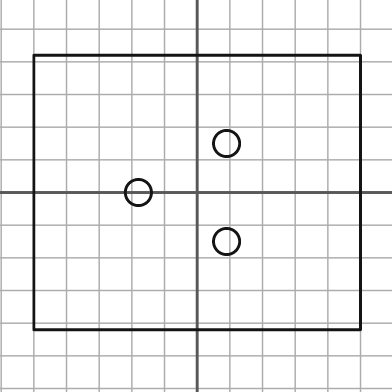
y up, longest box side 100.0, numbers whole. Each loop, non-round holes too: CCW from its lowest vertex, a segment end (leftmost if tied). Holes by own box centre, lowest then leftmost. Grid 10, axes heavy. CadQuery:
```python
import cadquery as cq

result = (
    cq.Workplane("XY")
    .moveTo(-50.0, -42.0)
    .lineTo(50.0, -42.0)
    .lineTo(50.0, 42.0)
    .lineTo(-50.0, 42.0)
    .close()
    .moveTo(9.0, -15.0)
    .circle(4.0)
    .moveTo(-18.0, 0.0)
    .circle(4.0)
    .moveTo(9.0, 15.0)
    .circle(4.0)
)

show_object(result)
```